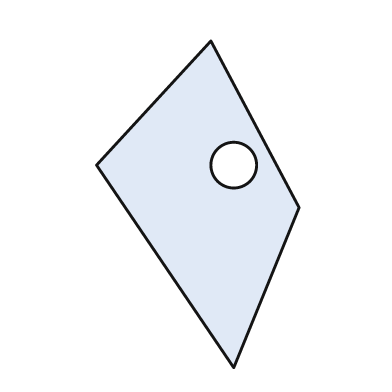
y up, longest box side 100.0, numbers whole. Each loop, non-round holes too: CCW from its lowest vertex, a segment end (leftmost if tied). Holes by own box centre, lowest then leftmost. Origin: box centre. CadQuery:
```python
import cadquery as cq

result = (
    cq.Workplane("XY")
    .moveTo(11.0, -50.0)
    .lineTo(31.0, -1.0)
    .lineTo(4.0, 50.0)
    .lineTo(-31.0, 12.0)
    .close()
    .moveTo(11.0, 12.0)
    .circle(7.0)
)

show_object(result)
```